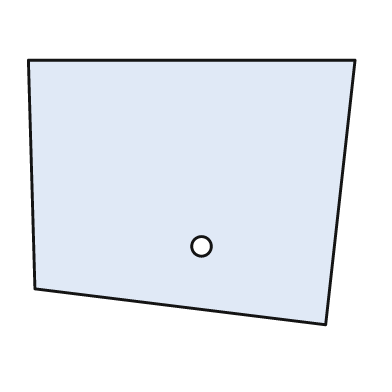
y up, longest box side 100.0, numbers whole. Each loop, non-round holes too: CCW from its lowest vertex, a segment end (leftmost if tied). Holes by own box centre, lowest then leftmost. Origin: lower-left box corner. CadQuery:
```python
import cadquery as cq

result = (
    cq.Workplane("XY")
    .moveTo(91.0, 0.0)
    .lineTo(100.0, 81.0)
    .lineTo(0.0, 81.0)
    .lineTo(2.0, 11.0)
    .close()
    .moveTo(53.0, 24.0)
    .circle(3.0)
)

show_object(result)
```